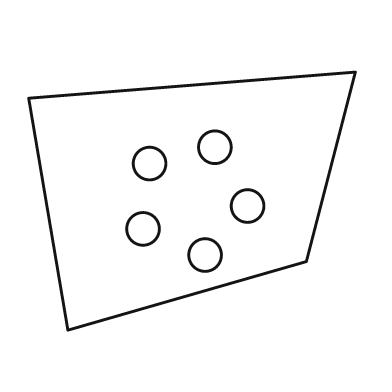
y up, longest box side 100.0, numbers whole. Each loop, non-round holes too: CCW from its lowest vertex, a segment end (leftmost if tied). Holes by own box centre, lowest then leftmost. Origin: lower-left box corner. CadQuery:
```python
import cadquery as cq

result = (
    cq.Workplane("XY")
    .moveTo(12.0, 0.0)
    .lineTo(85.0, 21.0)
    .lineTo(100.0, 79.0)
    .lineTo(0.0, 71.0)
    .close()
    .moveTo(54.0, 23.0)
    .circle(5.0)
    .moveTo(35.0, 31.0)
    .circle(5.0)
    .moveTo(67.0, 38.0)
    .circle(5.0)
    .moveTo(37.0, 51.0)
    .circle(5.0)
    .moveTo(57.0, 56.0)
    .circle(5.0)
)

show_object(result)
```